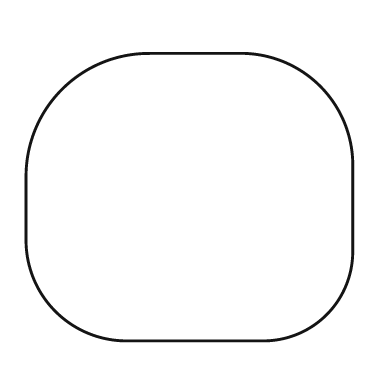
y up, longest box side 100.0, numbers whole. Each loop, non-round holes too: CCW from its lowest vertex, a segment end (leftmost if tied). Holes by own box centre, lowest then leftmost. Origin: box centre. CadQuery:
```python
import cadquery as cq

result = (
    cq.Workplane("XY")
    .moveTo(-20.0, -44.0)
    .lineTo(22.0, -44.0)
    .threePointArc((42.0, -36.0), (50.0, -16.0))
    .lineTo(50.0, 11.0)
    .threePointArc((40.0, 34.0), (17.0, 44.0))
    .lineTo(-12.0, 44.0)
    .threePointArc((-39.0, 33.0), (-50.0, 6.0))
    .lineTo(-50.0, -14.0)
    .threePointArc((-41.0, -35.0), (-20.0, -44.0))
    .close()
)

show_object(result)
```